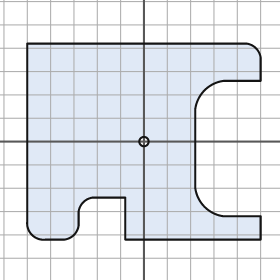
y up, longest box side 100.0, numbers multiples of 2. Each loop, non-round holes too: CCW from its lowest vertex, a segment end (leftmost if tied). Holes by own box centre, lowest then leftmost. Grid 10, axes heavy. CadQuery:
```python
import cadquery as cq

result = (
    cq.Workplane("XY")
    .moveTo(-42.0, -42.0)
    .lineTo(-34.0, -42.0)
    .threePointArc((-30.0, -40.0), (-28.0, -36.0))
    .lineTo(-28.0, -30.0)
    .threePointArc((-26.0, -26.0), (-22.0, -24.0))
    .lineTo(-8.0, -24.0)
    .lineTo(-8.0, -42.0)
    .lineTo(50.0, -42.0)
    .lineTo(50.0, -32.0)
    .lineTo(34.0, -32.0)
    .threePointArc((26.0, -28.0), (22.0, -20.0))
    .lineTo(22.0, 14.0)
    .threePointArc((26.0, 22.0), (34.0, 26.0))
    .lineTo(50.0, 26.0)
    .lineTo(50.0, 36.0)
    .threePointArc((48.0, 40.0), (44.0, 42.0))
    .lineTo(-50.0, 42.0)
    .lineTo(-50.0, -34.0)
    .threePointArc((-48.0, -40.0), (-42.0, -42.0))
    .close()
    .moveTo(0.0, 0.0)
    .circle(2.0)
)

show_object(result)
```